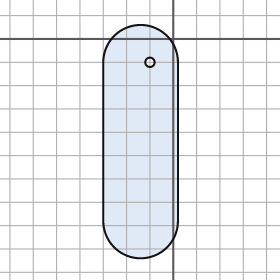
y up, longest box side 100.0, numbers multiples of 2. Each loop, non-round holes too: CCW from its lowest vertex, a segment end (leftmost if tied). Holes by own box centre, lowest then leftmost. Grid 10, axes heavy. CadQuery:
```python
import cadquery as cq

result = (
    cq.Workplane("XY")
    .moveTo(-30.0, -78.0)
    .threePointArc((-14.0, -94.0), (2.0, -78.0))
    .lineTo(2.0, -10.0)
    .threePointArc((-14.0, 6.0), (-30.0, -10.0))
    .close()
    .moveTo(-10.0, -10.0)
    .circle(2.0)
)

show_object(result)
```